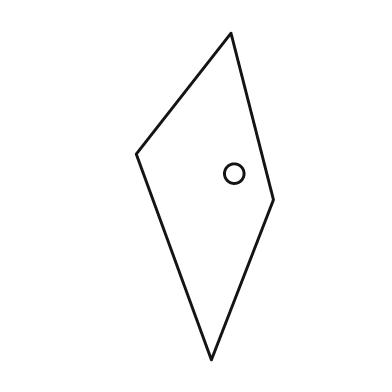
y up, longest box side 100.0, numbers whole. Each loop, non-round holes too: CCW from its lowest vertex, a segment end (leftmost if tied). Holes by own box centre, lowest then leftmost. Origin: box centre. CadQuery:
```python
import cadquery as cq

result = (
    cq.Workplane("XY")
    .moveTo(2.0, -50.0)
    .lineTo(21.0, -1.0)
    .lineTo(8.0, 50.0)
    .lineTo(-21.0, 13.0)
    .close()
    .moveTo(9.0, 7.0)
    .circle(3.0)
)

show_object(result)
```